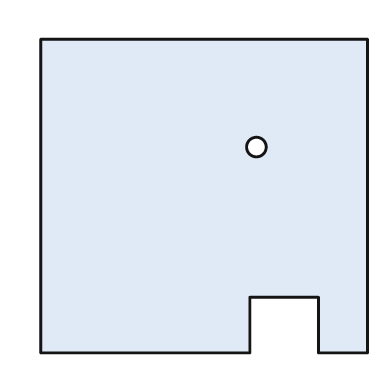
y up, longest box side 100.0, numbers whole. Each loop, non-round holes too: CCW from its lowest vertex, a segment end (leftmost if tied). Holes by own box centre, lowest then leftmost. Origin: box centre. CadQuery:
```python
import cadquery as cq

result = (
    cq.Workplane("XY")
    .moveTo(-50.0, -48.0)
    .lineTo(14.0, -48.0)
    .lineTo(14.0, -31.0)
    .lineTo(35.0, -31.0)
    .lineTo(35.0, -48.0)
    .lineTo(50.0, -48.0)
    .lineTo(50.0, 48.0)
    .lineTo(-50.0, 48.0)
    .close()
    .moveTo(16.0, 15.0)
    .circle(3.0)
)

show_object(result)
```